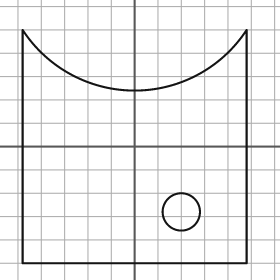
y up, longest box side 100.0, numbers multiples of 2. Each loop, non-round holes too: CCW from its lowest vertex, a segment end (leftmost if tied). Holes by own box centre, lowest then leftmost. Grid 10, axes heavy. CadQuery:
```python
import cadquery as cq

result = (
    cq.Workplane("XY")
    .moveTo(-48.0, -50.0)
    .lineTo(48.0, -50.0)
    .lineTo(48.0, 50.0)
    .threePointArc((0.0, 24.0), (-48.0, 50.0))
    .close()
    .moveTo(20.0, -28.0)
    .circle(8.0)
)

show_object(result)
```